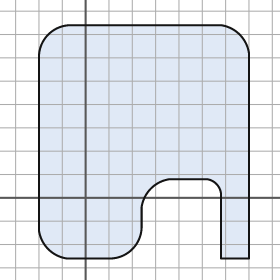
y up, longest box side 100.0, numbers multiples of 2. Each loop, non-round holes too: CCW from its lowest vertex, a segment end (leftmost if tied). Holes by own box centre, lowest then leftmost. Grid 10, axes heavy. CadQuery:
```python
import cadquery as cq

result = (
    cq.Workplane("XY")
    .moveTo(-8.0, -26.0)
    .lineTo(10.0, -26.0)
    .threePointArc((20.0, -22.0), (24.0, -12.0))
    .lineTo(24.0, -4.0)
    .threePointArc((28.0, 4.0), (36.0, 8.0))
    .lineTo(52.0, 8.0)
    .threePointArc((56.0, 6.0), (58.0, 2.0))
    .lineTo(58.0, -26.0)
    .lineTo(70.0, -26.0)
    .lineTo(70.0, 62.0)
    .threePointArc((66.0, 70.0), (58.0, 74.0))
    .lineTo(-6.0, 74.0)
    .threePointArc((-16.0, 70.0), (-20.0, 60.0))
    .lineTo(-20.0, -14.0)
    .threePointArc((-16.0, -22.0), (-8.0, -26.0))
    .close()
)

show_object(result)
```